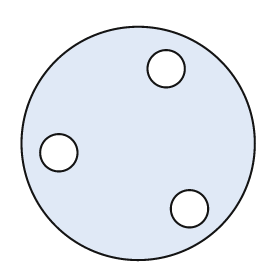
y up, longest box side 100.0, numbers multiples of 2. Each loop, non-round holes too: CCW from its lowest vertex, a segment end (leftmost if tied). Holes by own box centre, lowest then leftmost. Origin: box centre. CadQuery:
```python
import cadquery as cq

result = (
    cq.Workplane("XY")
    .moveTo(0.0, 0.0)
    .circle(50.0)
    .moveTo(22.0, -28.0)
    .circle(8.0)
    .moveTo(-34.0, -4.0)
    .circle(8.0)
    .moveTo(12.0, 32.0)
    .circle(8.0)
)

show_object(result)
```